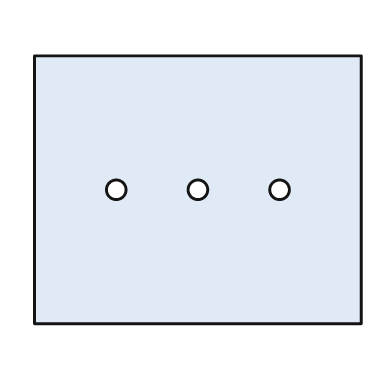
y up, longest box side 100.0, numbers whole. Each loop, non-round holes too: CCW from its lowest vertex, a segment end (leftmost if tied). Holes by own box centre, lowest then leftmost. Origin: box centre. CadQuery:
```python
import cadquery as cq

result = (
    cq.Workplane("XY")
    .moveTo(-50.0, -41.0)
    .lineTo(50.0, -41.0)
    .lineTo(50.0, 41.0)
    .lineTo(-50.0, 41.0)
    .close()
    .moveTo(-25.0, 0.0)
    .circle(3.0)
    .moveTo(0.0, 0.0)
    .circle(3.0)
    .moveTo(25.0, 0.0)
    .circle(3.0)
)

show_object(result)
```